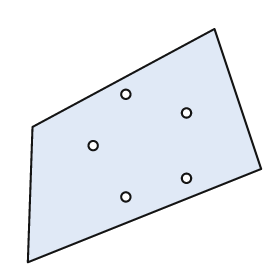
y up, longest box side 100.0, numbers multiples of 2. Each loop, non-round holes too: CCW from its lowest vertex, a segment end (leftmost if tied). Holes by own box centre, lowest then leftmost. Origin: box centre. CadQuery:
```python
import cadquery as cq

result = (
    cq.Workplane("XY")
    .moveTo(-50.0, -50.0)
    .lineTo(50.0, -10.0)
    .lineTo(30.0, 50.0)
    .lineTo(-48.0, 8.0)
    .close()
    .moveTo(-8.0, -22.0)
    .circle(2.0)
    .moveTo(18.0, -14.0)
    .circle(2.0)
    .moveTo(-22.0, 0.0)
    .circle(2.0)
    .moveTo(18.0, 14.0)
    .circle(2.0)
    .moveTo(-8.0, 22.0)
    .circle(2.0)
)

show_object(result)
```